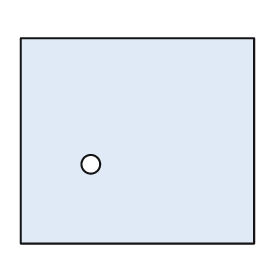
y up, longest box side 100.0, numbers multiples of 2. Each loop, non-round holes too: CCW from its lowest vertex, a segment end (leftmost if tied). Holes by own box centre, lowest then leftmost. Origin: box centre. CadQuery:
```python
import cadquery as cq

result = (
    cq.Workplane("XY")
    .moveTo(-50.0, -44.0)
    .lineTo(50.0, -44.0)
    .lineTo(50.0, 44.0)
    .lineTo(-50.0, 44.0)
    .close()
    .moveTo(-20.0, -10.0)
    .circle(4.0)
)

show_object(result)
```